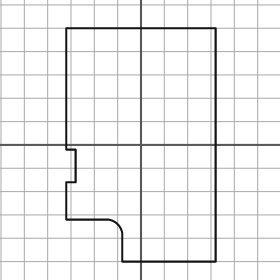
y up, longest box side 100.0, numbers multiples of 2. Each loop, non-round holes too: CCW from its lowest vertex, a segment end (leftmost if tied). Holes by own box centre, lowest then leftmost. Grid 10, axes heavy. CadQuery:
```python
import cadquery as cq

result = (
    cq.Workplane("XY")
    .moveTo(-8.0, -50.0)
    .lineTo(32.0, -50.0)
    .lineTo(32.0, 50.0)
    .lineTo(-32.0, 50.0)
    .lineTo(-32.0, -2.0)
    .lineTo(-28.0, -2.0)
    .lineTo(-28.0, -16.0)
    .lineTo(-32.0, -16.0)
    .lineTo(-32.0, -32.0)
    .lineTo(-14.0, -32.0)
    .threePointArc((-10.0, -34.0), (-8.0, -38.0))
    .close()
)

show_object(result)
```